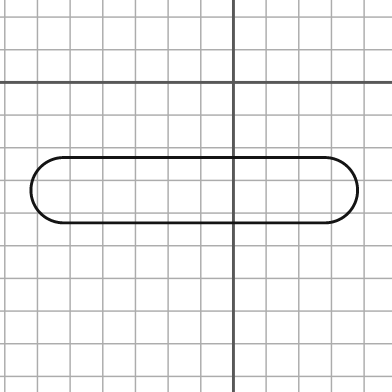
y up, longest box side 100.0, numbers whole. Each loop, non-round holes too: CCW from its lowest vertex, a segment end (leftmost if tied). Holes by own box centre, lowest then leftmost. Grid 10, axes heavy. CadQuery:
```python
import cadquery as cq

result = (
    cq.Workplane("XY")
    .moveTo(-52.0, -43.0)
    .lineTo(28.0, -43.0)
    .threePointArc((38.0, -33.0), (28.0, -23.0))
    .lineTo(-52.0, -23.0)
    .threePointArc((-62.0, -33.0), (-52.0, -43.0))
    .close()
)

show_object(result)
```